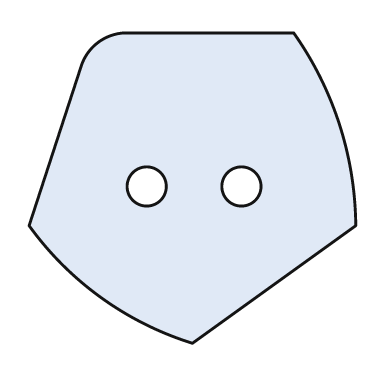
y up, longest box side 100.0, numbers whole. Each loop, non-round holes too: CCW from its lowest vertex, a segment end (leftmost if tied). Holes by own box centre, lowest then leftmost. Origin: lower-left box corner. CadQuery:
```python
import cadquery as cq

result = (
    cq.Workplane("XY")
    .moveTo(50.0, 0.0)
    .lineTo(100.0, 36.0)
    .threePointArc((95.0, 67.0), (81.0, 95.0))
    .lineTo(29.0, 95.0)
    .threePointArc((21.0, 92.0), (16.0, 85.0))
    .lineTo(0.0, 36.0)
    .threePointArc((22.0, 14.0), (50.0, 0.0))
    .close()
    .moveTo(36.0, 48.0)
    .circle(6.0)
    .moveTo(65.0, 48.0)
    .circle(6.0)
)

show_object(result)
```